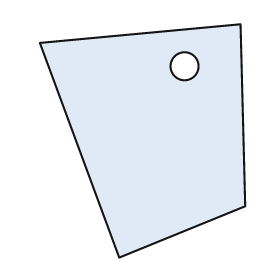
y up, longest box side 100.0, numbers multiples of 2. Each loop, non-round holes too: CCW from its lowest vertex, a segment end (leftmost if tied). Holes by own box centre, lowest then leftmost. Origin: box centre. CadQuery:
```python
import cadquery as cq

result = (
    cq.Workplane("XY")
    .moveTo(-10.0, -50.0)
    .lineTo(44.0, -28.0)
    .lineTo(42.0, 50.0)
    .lineTo(-44.0, 42.0)
    .close()
    .moveTo(18.0, 32.0)
    .circle(6.0)
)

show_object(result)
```